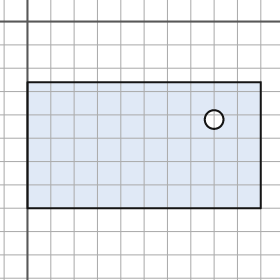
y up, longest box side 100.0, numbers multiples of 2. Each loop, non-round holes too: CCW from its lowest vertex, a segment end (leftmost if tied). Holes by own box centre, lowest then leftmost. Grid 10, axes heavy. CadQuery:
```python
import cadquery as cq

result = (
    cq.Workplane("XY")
    .moveTo(0.0, -80.0)
    .lineTo(100.0, -80.0)
    .lineTo(100.0, -26.0)
    .lineTo(0.0, -26.0)
    .close()
    .moveTo(80.0, -42.0)
    .circle(4.0)
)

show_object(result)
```